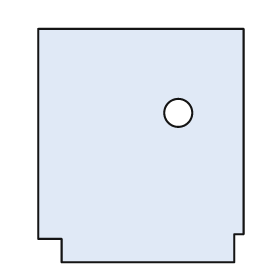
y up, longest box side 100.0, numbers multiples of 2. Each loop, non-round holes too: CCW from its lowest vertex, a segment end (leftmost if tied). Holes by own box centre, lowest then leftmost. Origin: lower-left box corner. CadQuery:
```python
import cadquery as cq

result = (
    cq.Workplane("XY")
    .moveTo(10.0, 0.0)
    .lineTo(84.0, 0.0)
    .lineTo(84.0, 12.0)
    .lineTo(88.0, 12.0)
    .lineTo(88.0, 100.0)
    .lineTo(0.0, 100.0)
    .lineTo(0.0, 10.0)
    .lineTo(10.0, 10.0)
    .close()
    .moveTo(60.0, 64.0)
    .circle(6.0)
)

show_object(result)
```